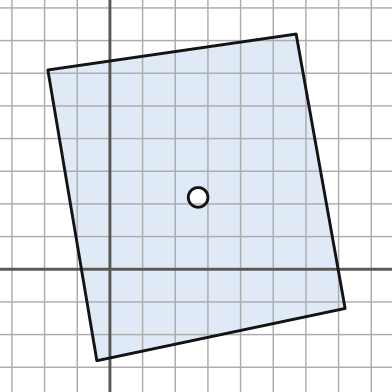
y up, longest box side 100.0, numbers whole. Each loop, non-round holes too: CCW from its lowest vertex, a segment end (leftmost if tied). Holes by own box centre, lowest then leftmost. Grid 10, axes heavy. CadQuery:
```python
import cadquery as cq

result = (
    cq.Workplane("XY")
    .moveTo(-4.0, -28.0)
    .lineTo(72.0, -12.0)
    .lineTo(57.0, 72.0)
    .lineTo(-19.0, 61.0)
    .close()
    .moveTo(27.0, 22.0)
    .circle(3.0)
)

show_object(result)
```